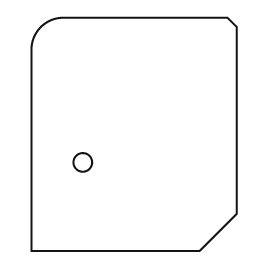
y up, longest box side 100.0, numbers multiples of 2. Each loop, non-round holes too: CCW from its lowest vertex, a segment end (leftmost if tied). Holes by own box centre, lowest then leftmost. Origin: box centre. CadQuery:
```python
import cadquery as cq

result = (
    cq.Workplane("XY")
    .moveTo(-44.0, -50.0)
    .lineTo(28.0, -50.0)
    .lineTo(44.0, -34.0)
    .lineTo(44.0, 46.0)
    .lineTo(40.0, 50.0)
    .lineTo(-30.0, 50.0)
    .threePointArc((-40.0, 46.0), (-44.0, 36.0))
    .close()
    .moveTo(-22.0, -12.0)
    .circle(4.0)
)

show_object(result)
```